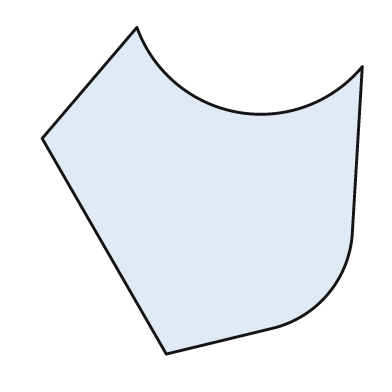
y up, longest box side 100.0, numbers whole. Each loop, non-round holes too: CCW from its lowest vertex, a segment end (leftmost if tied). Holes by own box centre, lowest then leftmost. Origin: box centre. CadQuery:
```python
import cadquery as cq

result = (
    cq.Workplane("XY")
    .moveTo(-11.0, -50.0)
    .lineTo(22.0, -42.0)
    .threePointArc((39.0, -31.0), (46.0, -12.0))
    .lineTo(49.0, 38.0)
    .threePointArc((11.0, 24.0), (-20.0, 50.0))
    .lineTo(-49.0, 16.0)
    .close()
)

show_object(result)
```